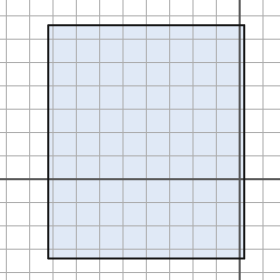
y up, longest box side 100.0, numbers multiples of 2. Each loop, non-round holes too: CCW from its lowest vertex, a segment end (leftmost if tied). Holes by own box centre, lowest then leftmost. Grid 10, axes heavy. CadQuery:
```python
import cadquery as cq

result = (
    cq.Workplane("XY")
    .moveTo(-82.0, -34.0)
    .lineTo(2.0, -34.0)
    .lineTo(2.0, 66.0)
    .lineTo(-82.0, 66.0)
    .close()
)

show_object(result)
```